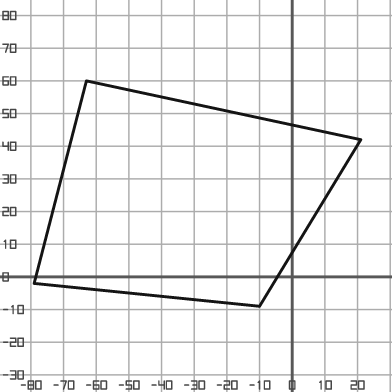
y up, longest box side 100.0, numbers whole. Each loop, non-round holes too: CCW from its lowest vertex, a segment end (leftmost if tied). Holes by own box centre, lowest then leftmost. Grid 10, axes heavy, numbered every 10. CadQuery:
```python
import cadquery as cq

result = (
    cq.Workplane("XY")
    .moveTo(-10.0, -9.0)
    .lineTo(21.0, 42.0)
    .lineTo(-63.0, 60.0)
    .lineTo(-79.0, -2.0)
    .close()
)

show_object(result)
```